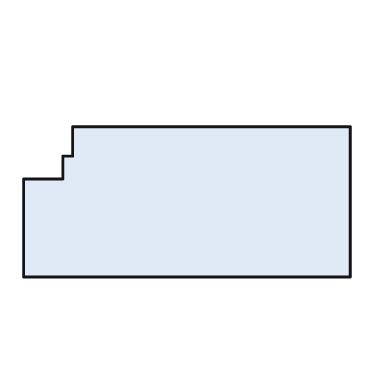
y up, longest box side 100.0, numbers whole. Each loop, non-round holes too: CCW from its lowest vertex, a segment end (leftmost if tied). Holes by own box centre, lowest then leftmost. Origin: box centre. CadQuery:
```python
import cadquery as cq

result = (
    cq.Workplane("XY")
    .moveTo(-50.0, -23.0)
    .lineTo(50.0, -23.0)
    .lineTo(50.0, 23.0)
    .lineTo(-35.0, 23.0)
    .lineTo(-35.0, 14.0)
    .lineTo(-38.0, 14.0)
    .lineTo(-38.0, 7.0)
    .lineTo(-50.0, 7.0)
    .close()
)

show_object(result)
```